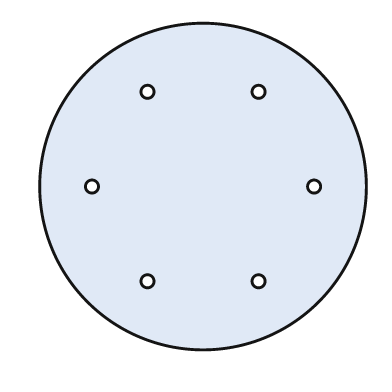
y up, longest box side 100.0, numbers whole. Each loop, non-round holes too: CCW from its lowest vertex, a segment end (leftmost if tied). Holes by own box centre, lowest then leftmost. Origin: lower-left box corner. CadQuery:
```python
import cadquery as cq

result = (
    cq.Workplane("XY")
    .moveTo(50.0, 50.0)
    .circle(50.0)
    .moveTo(33.0, 21.0)
    .circle(2.0)
    .moveTo(67.0, 21.0)
    .circle(2.0)
    .moveTo(16.0, 50.0)
    .circle(2.0)
    .moveTo(84.0, 50.0)
    .circle(2.0)
    .moveTo(33.0, 79.0)
    .circle(2.0)
    .moveTo(67.0, 79.0)
    .circle(2.0)
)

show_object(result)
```